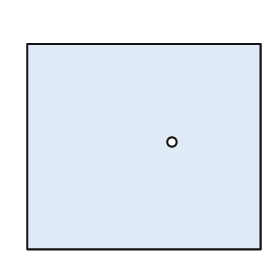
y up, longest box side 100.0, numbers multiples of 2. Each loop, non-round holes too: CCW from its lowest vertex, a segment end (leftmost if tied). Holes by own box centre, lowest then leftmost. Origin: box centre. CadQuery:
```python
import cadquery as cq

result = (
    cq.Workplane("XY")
    .moveTo(-50.0, -44.0)
    .lineTo(50.0, -44.0)
    .lineTo(50.0, 44.0)
    .lineTo(-50.0, 44.0)
    .close()
    .moveTo(12.0, 2.0)
    .circle(2.0)
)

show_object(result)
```